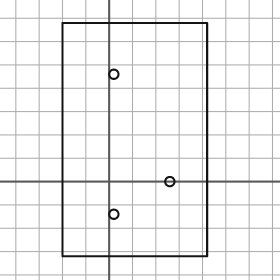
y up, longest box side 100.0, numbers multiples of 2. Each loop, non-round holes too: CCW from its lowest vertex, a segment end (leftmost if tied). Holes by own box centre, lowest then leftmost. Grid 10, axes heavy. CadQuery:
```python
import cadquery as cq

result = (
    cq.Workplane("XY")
    .moveTo(-20.0, -32.0)
    .lineTo(42.0, -32.0)
    .lineTo(42.0, 68.0)
    .lineTo(-20.0, 68.0)
    .close()
    .moveTo(2.0, -14.0)
    .circle(2.0)
    .moveTo(26.0, 0.0)
    .circle(2.0)
    .moveTo(2.0, 46.0)
    .circle(2.0)
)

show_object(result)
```